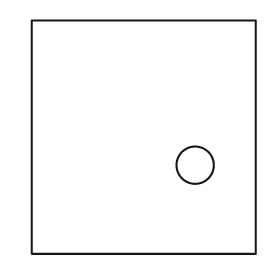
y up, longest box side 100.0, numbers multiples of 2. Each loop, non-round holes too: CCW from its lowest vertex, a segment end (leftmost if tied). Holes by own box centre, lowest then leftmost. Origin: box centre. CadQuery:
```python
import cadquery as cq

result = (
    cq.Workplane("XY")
    .moveTo(-48.0, -50.0)
    .lineTo(48.0, -50.0)
    .lineTo(48.0, 50.0)
    .lineTo(-48.0, 50.0)
    .close()
    .moveTo(22.0, -12.0)
    .circle(8.0)
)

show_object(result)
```